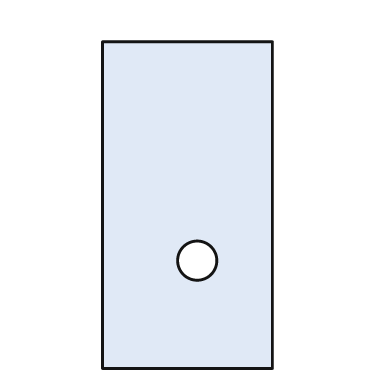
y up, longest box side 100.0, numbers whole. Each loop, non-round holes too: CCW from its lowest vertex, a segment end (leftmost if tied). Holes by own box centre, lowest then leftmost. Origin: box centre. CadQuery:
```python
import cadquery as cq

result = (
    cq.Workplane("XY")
    .moveTo(-26.0, -50.0)
    .lineTo(26.0, -50.0)
    .lineTo(26.0, 50.0)
    .lineTo(-26.0, 50.0)
    .close()
    .moveTo(3.0, -17.0)
    .circle(6.0)
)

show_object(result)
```